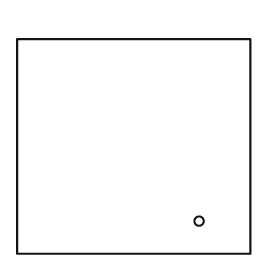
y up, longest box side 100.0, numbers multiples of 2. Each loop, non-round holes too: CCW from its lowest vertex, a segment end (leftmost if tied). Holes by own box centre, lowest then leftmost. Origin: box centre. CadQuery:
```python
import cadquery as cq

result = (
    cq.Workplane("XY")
    .moveTo(-50.0, -46.0)
    .lineTo(50.0, -46.0)
    .lineTo(50.0, 46.0)
    .lineTo(-50.0, 46.0)
    .close()
    .moveTo(28.0, -32.0)
    .circle(2.0)
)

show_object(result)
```